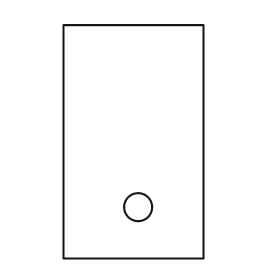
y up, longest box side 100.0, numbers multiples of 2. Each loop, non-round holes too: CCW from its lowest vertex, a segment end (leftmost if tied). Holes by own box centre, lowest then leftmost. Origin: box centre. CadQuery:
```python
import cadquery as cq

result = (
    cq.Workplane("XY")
    .moveTo(-30.0, -50.0)
    .lineTo(30.0, -50.0)
    .lineTo(30.0, 50.0)
    .lineTo(-30.0, 50.0)
    .close()
    .moveTo(2.0, -28.0)
    .circle(6.0)
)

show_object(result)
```